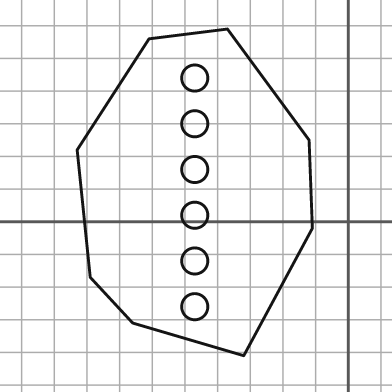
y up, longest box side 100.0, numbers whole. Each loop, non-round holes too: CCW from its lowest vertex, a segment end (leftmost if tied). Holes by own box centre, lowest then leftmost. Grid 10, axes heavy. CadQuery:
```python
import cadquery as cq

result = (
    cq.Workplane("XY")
    .moveTo(-32.0, -41.0)
    .lineTo(-11.0, -2.0)
    .lineTo(-12.0, 25.0)
    .lineTo(-37.0, 59.0)
    .lineTo(-61.0, 56.0)
    .lineTo(-83.0, 22.0)
    .lineTo(-79.0, -17.0)
    .lineTo(-66.0, -31.0)
    .close()
    .moveTo(-47.0, -26.0)
    .circle(4.0)
    .moveTo(-47.0, -12.0)
    .circle(4.0)
    .moveTo(-47.0, 2.0)
    .circle(4.0)
    .moveTo(-47.0, 16.0)
    .circle(4.0)
    .moveTo(-47.0, 30.0)
    .circle(4.0)
    .moveTo(-47.0, 44.0)
    .circle(4.0)
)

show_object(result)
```